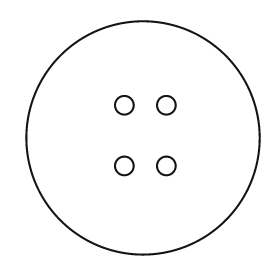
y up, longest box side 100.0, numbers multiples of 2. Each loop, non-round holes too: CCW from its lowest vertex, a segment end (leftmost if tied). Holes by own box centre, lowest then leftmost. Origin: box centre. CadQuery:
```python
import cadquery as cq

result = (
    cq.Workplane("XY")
    .moveTo(0.0, 0.0)
    .circle(50.0)
    .moveTo(-8.0, -12.0)
    .circle(4.0)
    .moveTo(10.0, -12.0)
    .circle(4.0)
    .moveTo(-8.0, 14.0)
    .circle(4.0)
    .moveTo(10.0, 14.0)
    .circle(4.0)
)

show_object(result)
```